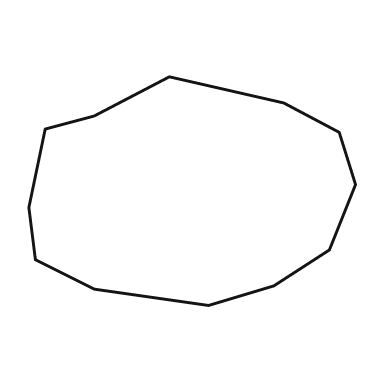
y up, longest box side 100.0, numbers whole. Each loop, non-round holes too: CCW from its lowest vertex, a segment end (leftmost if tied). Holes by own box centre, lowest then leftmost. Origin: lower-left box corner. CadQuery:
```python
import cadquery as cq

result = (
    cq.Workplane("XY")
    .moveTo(55.0, 0.0)
    .lineTo(75.0, 6.0)
    .lineTo(92.0, 17.0)
    .lineTo(100.0, 37.0)
    .lineTo(95.0, 53.0)
    .lineTo(78.0, 62.0)
    .lineTo(43.0, 70.0)
    .lineTo(20.0, 58.0)
    .lineTo(5.0, 54.0)
    .lineTo(0.0, 30.0)
    .lineTo(2.0, 14.0)
    .lineTo(20.0, 5.0)
    .close()
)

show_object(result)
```